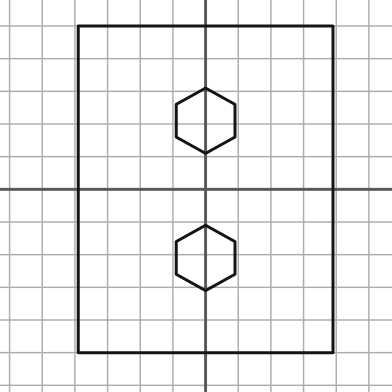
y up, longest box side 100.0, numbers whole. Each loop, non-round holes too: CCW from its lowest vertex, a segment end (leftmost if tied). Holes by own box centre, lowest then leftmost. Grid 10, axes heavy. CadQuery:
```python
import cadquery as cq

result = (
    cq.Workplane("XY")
    .moveTo(-39.0, -50.0)
    .lineTo(39.0, -50.0)
    .lineTo(39.0, 50.0)
    .lineTo(-39.0, 50.0)
    .close()
    .moveTo(0.0, -31.0)
    .lineTo(9.0, -26.0)
    .lineTo(9.0, -16.0)
    .lineTo(0.0, -11.0)
    .lineTo(-9.0, -16.0)
    .lineTo(-9.0, -26.0)
    .close()
    .moveTo(0.0, 11.0)
    .lineTo(9.0, 16.0)
    .lineTo(9.0, 26.0)
    .lineTo(0.0, 31.0)
    .lineTo(-9.0, 26.0)
    .lineTo(-9.0, 16.0)
    .close()
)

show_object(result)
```